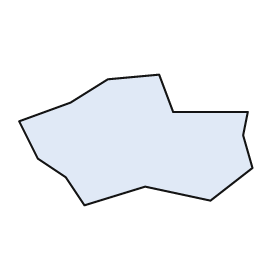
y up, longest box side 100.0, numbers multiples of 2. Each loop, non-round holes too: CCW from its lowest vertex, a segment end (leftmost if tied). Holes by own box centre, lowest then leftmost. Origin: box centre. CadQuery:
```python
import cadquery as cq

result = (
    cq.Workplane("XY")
    .moveTo(-22.0, -28.0)
    .lineTo(4.0, -20.0)
    .lineTo(32.0, -26.0)
    .lineTo(50.0, -12.0)
    .lineTo(46.0, 2.0)
    .lineTo(48.0, 12.0)
    .lineTo(16.0, 12.0)
    .lineTo(10.0, 28.0)
    .lineTo(-12.0, 26.0)
    .lineTo(-28.0, 16.0)
    .lineTo(-50.0, 8.0)
    .lineTo(-42.0, -8.0)
    .lineTo(-30.0, -16.0)
    .close()
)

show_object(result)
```